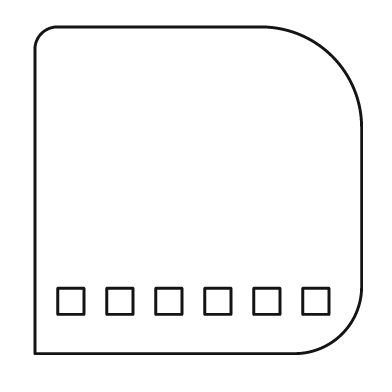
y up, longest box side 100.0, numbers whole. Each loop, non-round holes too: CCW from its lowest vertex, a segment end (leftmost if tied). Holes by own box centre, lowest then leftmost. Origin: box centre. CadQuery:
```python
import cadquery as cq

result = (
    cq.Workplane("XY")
    .moveTo(-50.0, -50.0)
    .lineTo(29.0, -50.0)
    .threePointArc((44.0, -44.0), (50.0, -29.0))
    .lineTo(50.0, 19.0)
    .threePointArc((41.0, 41.0), (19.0, 50.0))
    .lineTo(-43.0, 50.0)
    .threePointArc((-48.0, 48.0), (-50.0, 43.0))
    .close()
    .moveTo(-43.0, -38.0)
    .lineTo(-35.0, -38.0)
    .lineTo(-35.0, -30.0)
    .lineTo(-43.0, -30.0)
    .close()
    .moveTo(-28.0, -38.0)
    .lineTo(-20.0, -38.0)
    .lineTo(-20.0, -30.0)
    .lineTo(-28.0, -30.0)
    .close()
    .moveTo(-13.0, -38.0)
    .lineTo(-5.0, -38.0)
    .lineTo(-5.0, -30.0)
    .lineTo(-13.0, -30.0)
    .close()
    .moveTo(2.0, -38.0)
    .lineTo(10.0, -38.0)
    .lineTo(10.0, -30.0)
    .lineTo(2.0, -30.0)
    .close()
    .moveTo(17.0, -38.0)
    .lineTo(25.0, -38.0)
    .lineTo(25.0, -30.0)
    .lineTo(17.0, -30.0)
    .close()
    .moveTo(32.0, -38.0)
    .lineTo(40.0, -38.0)
    .lineTo(40.0, -30.0)
    .lineTo(32.0, -30.0)
    .close()
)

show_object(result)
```